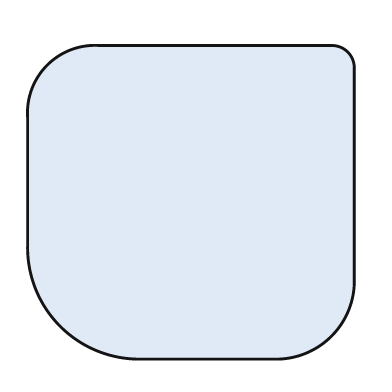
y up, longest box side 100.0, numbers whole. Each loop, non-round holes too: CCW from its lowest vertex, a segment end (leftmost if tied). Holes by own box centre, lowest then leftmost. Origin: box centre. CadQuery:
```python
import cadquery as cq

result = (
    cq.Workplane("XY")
    .moveTo(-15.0, -48.0)
    .lineTo(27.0, -48.0)
    .threePointArc((43.0, -41.0), (50.0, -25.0))
    .lineTo(50.0, 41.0)
    .threePointArc((48.0, 46.0), (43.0, 48.0))
    .lineTo(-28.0, 48.0)
    .threePointArc((-44.0, 42.0), (-50.0, 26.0))
    .lineTo(-50.0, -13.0)
    .threePointArc((-40.0, -38.0), (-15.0, -48.0))
    .close()
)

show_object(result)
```